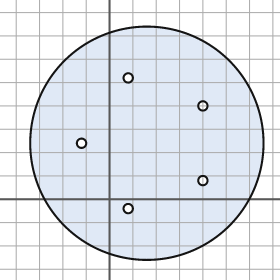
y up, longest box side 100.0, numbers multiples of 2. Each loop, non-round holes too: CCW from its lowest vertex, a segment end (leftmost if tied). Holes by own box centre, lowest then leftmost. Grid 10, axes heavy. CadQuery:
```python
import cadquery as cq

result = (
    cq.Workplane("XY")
    .moveTo(16.0, 24.0)
    .circle(50.0)
    .moveTo(8.0, -4.0)
    .circle(2.0)
    .moveTo(40.0, 8.0)
    .circle(2.0)
    .moveTo(-12.0, 24.0)
    .circle(2.0)
    .moveTo(40.0, 40.0)
    .circle(2.0)
    .moveTo(8.0, 52.0)
    .circle(2.0)
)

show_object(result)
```